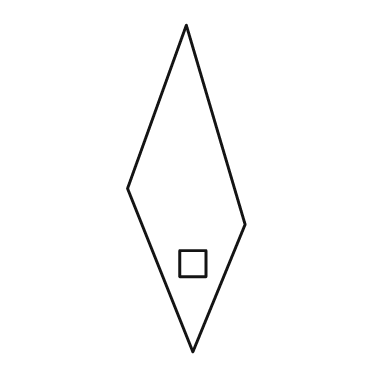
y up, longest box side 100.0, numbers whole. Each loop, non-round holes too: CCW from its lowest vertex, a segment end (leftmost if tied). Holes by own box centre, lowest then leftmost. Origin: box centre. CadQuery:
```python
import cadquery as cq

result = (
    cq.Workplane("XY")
    .moveTo(2.0, -50.0)
    .lineTo(18.0, -11.0)
    .lineTo(0.0, 50.0)
    .lineTo(-18.0, 0.0)
    .close()
    .moveTo(-2.0, -27.0)
    .lineTo(6.0, -27.0)
    .lineTo(6.0, -19.0)
    .lineTo(-2.0, -19.0)
    .close()
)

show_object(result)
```